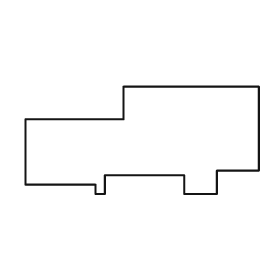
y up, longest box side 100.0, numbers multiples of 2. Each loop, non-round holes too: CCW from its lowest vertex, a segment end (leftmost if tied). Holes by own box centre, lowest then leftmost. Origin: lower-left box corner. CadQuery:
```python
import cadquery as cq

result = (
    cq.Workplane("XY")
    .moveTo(30.0, 0.0)
    .lineTo(34.0, 0.0)
    .lineTo(34.0, 8.0)
    .lineTo(68.0, 8.0)
    .lineTo(68.0, 0.0)
    .lineTo(82.0, 0.0)
    .lineTo(82.0, 10.0)
    .lineTo(100.0, 10.0)
    .lineTo(100.0, 46.0)
    .lineTo(42.0, 46.0)
    .lineTo(42.0, 32.0)
    .lineTo(0.0, 32.0)
    .lineTo(0.0, 4.0)
    .lineTo(30.0, 4.0)
    .close()
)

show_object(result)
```